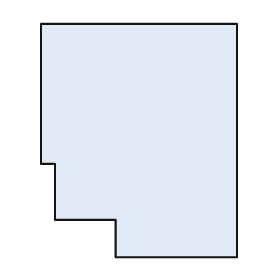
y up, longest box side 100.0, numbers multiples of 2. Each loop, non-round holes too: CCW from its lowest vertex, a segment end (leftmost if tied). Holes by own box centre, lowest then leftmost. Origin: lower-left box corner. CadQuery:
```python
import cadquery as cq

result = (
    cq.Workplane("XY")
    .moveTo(32.0, 0.0)
    .lineTo(84.0, 0.0)
    .lineTo(84.0, 100.0)
    .lineTo(0.0, 100.0)
    .lineTo(0.0, 40.0)
    .lineTo(6.0, 40.0)
    .lineTo(6.0, 16.0)
    .lineTo(32.0, 16.0)
    .close()
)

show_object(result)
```